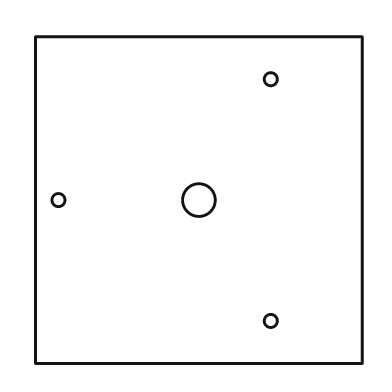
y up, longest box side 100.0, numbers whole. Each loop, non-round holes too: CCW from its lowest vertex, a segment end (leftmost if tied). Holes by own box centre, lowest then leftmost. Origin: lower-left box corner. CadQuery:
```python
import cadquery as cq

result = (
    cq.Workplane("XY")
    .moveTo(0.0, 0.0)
    .lineTo(100.0, 0.0)
    .lineTo(100.0, 100.0)
    .lineTo(0.0, 100.0)
    .close()
    .moveTo(72.0, 13.0)
    .circle(2.0)
    .moveTo(7.0, 50.0)
    .circle(2.0)
    .moveTo(50.0, 50.0)
    .circle(5.0)
    .moveTo(72.0, 87.0)
    .circle(2.0)
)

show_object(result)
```